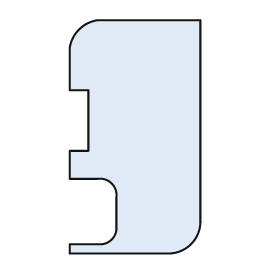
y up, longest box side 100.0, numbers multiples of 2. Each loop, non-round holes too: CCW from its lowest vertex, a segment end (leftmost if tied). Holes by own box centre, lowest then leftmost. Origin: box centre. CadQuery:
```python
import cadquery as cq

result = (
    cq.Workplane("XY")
    .moveTo(-28.0, -50.0)
    .lineTo(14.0, -50.0)
    .threePointArc((24.0, -46.0), (28.0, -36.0))
    .lineTo(28.0, 50.0)
    .lineTo(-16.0, 50.0)
    .threePointArc((-24.0, 46.0), (-28.0, 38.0))
    .lineTo(-28.0, 20.0)
    .lineTo(-20.0, 20.0)
    .lineTo(-20.0, -6.0)
    .lineTo(-28.0, -6.0)
    .lineTo(-28.0, -18.0)
    .lineTo(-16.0, -18.0)
    .threePointArc((-10.0, -20.0), (-8.0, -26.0))
    .lineTo(-8.0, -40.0)
    .threePointArc((-10.0, -44.0), (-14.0, -46.0))
    .lineTo(-28.0, -46.0)
    .close()
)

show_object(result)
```